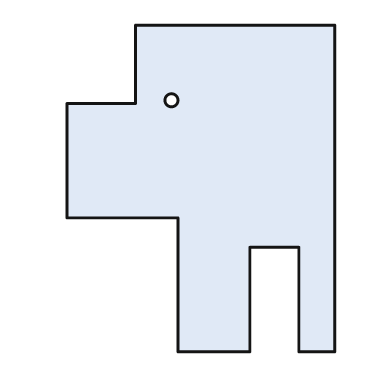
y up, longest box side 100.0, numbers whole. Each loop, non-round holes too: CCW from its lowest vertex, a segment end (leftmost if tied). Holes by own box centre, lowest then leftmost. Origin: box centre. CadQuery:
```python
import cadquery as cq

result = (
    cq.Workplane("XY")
    .moveTo(-7.0, -50.0)
    .lineTo(15.0, -50.0)
    .lineTo(15.0, -18.0)
    .lineTo(30.0, -18.0)
    .lineTo(30.0, -50.0)
    .lineTo(41.0, -50.0)
    .lineTo(41.0, 50.0)
    .lineTo(-20.0, 50.0)
    .lineTo(-20.0, 26.0)
    .lineTo(-41.0, 26.0)
    .lineTo(-41.0, -9.0)
    .lineTo(-7.0, -9.0)
    .close()
    .moveTo(-9.0, 27.0)
    .circle(2.0)
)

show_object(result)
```